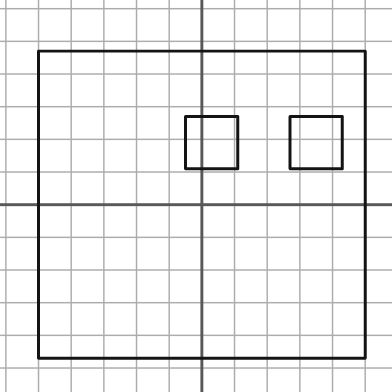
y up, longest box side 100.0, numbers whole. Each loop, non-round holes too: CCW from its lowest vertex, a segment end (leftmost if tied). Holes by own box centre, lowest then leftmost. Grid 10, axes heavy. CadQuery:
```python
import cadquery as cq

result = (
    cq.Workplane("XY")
    .moveTo(-50.0, -47.0)
    .lineTo(50.0, -47.0)
    .lineTo(50.0, 47.0)
    .lineTo(-50.0, 47.0)
    .close()
    .moveTo(-5.0, 11.0)
    .lineTo(11.0, 11.0)
    .lineTo(11.0, 27.0)
    .lineTo(-5.0, 27.0)
    .close()
    .moveTo(27.0, 11.0)
    .lineTo(43.0, 11.0)
    .lineTo(43.0, 27.0)
    .lineTo(27.0, 27.0)
    .close()
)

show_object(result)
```